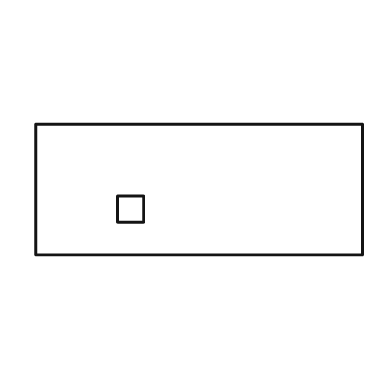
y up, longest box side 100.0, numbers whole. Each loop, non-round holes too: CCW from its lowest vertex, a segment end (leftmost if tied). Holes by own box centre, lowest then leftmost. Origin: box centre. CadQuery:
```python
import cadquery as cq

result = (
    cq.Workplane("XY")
    .moveTo(-50.0, -20.0)
    .lineTo(50.0, -20.0)
    .lineTo(50.0, 20.0)
    .lineTo(-50.0, 20.0)
    .close()
    .moveTo(-25.0, -10.0)
    .lineTo(-17.0, -10.0)
    .lineTo(-17.0, -2.0)
    .lineTo(-25.0, -2.0)
    .close()
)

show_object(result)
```